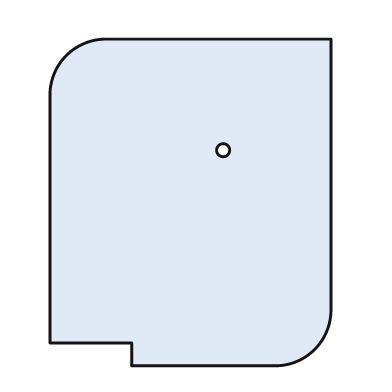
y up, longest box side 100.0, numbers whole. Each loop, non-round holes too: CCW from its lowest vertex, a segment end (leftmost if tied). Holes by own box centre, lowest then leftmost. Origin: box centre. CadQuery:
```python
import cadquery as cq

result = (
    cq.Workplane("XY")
    .moveTo(-18.0, -50.0)
    .lineTo(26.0, -50.0)
    .threePointArc((38.0, -45.0), (43.0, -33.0))
    .lineTo(43.0, 50.0)
    .lineTo(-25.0, 50.0)
    .threePointArc((-38.0, 45.0), (-43.0, 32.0))
    .lineTo(-43.0, -43.0)
    .lineTo(-18.0, -43.0)
    .close()
    .moveTo(10.0, 16.0)
    .circle(2.0)
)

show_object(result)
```